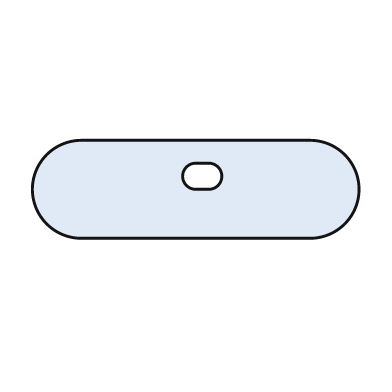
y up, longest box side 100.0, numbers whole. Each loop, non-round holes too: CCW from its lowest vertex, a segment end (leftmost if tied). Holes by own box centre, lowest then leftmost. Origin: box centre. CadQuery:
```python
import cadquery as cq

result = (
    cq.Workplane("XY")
    .moveTo(-35.0, -15.0)
    .lineTo(35.0, -15.0)
    .threePointArc((50.0, 0.0), (35.0, 15.0))
    .lineTo(-35.0, 15.0)
    .threePointArc((-50.0, 0.0), (-35.0, -15.0))
    .close()
    .moveTo(0.0, 0.0)
    .lineTo(4.0, 0.0)
    .threePointArc((8.0, 4.0), (4.0, 8.0))
    .lineTo(0.0, 8.0)
    .threePointArc((-4.0, 4.0), (0.0, 0.0))
    .close()
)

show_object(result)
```